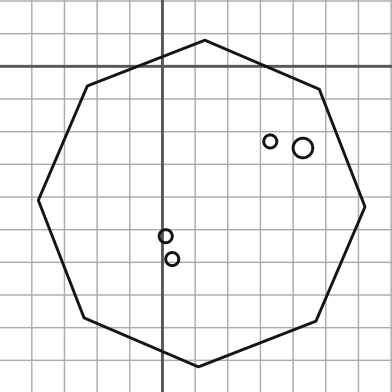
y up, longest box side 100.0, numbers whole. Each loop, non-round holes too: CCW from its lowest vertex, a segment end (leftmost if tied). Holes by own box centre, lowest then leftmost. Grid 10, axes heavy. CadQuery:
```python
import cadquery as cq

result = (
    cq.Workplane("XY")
    .moveTo(11.0, -92.0)
    .lineTo(47.0, -78.0)
    .lineTo(62.0, -43.0)
    .lineTo(48.0, -7.0)
    .lineTo(13.0, 8.0)
    .lineTo(-23.0, -6.0)
    .lineTo(-38.0, -41.0)
    .lineTo(-24.0, -77.0)
    .close()
    .moveTo(3.0, -59.0)
    .circle(2.0)
    .moveTo(1.0, -52.0)
    .circle(2.0)
    .moveTo(43.0, -25.0)
    .circle(3.0)
    .moveTo(33.0, -23.0)
    .circle(2.0)
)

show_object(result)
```